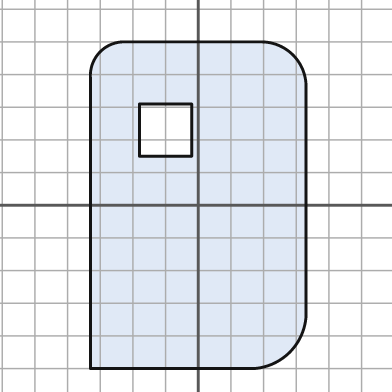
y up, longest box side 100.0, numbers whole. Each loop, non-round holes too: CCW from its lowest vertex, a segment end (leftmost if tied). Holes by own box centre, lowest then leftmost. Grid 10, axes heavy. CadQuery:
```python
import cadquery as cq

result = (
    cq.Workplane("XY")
    .moveTo(-33.0, -50.0)
    .lineTo(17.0, -50.0)
    .threePointArc((28.0, -45.0), (33.0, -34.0))
    .lineTo(33.0, 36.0)
    .threePointArc((29.0, 46.0), (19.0, 50.0))
    .lineTo(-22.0, 50.0)
    .threePointArc((-30.0, 47.0), (-33.0, 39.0))
    .close()
    .moveTo(-18.0, 15.0)
    .lineTo(-2.0, 15.0)
    .lineTo(-2.0, 31.0)
    .lineTo(-18.0, 31.0)
    .close()
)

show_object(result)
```